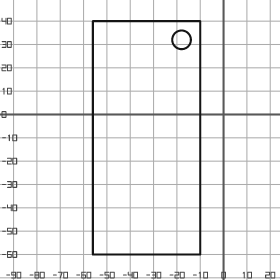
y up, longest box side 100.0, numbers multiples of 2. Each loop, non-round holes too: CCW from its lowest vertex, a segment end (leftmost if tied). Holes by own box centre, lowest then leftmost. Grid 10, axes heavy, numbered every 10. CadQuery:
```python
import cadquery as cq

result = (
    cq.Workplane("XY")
    .moveTo(-56.0, -60.0)
    .lineTo(-10.0, -60.0)
    .lineTo(-10.0, 40.0)
    .lineTo(-56.0, 40.0)
    .close()
    .moveTo(-18.0, 32.0)
    .circle(4.0)
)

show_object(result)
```